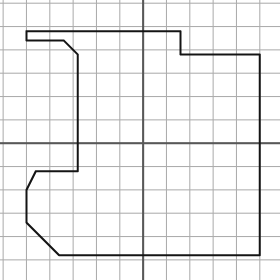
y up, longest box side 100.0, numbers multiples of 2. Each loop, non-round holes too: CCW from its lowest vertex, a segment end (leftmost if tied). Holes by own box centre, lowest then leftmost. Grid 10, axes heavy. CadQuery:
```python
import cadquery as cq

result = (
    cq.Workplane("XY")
    .moveTo(-36.0, -48.0)
    .lineTo(50.0, -48.0)
    .lineTo(50.0, 38.0)
    .lineTo(16.0, 38.0)
    .lineTo(16.0, 48.0)
    .lineTo(-50.0, 48.0)
    .lineTo(-50.0, 44.0)
    .lineTo(-34.0, 44.0)
    .lineTo(-28.0, 38.0)
    .lineTo(-28.0, -12.0)
    .lineTo(-46.0, -12.0)
    .lineTo(-50.0, -20.0)
    .lineTo(-50.0, -34.0)
    .close()
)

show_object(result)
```